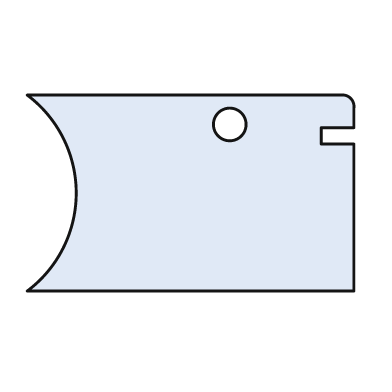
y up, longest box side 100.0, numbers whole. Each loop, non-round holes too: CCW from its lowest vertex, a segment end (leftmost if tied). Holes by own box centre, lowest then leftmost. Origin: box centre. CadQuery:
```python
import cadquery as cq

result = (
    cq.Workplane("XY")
    .moveTo(-50.0, -30.0)
    .lineTo(50.0, -30.0)
    .lineTo(50.0, 15.0)
    .lineTo(40.0, 15.0)
    .lineTo(40.0, 20.0)
    .lineTo(50.0, 20.0)
    .lineTo(50.0, 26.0)
    .threePointArc((49.0, 29.0), (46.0, 30.0))
    .lineTo(-50.0, 30.0)
    .threePointArc((-35.0, 0.0), (-50.0, -30.0))
    .close()
    .moveTo(12.0, 21.0)
    .circle(5.0)
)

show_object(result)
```